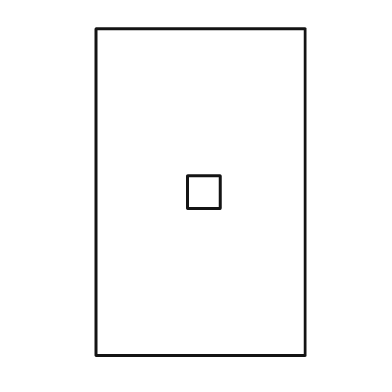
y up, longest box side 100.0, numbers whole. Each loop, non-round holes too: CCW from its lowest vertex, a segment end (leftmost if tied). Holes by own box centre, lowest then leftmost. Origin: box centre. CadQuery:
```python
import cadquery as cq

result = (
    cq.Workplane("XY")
    .moveTo(-32.0, -50.0)
    .lineTo(32.0, -50.0)
    .lineTo(32.0, 50.0)
    .lineTo(-32.0, 50.0)
    .close()
    .moveTo(-4.0, -5.0)
    .lineTo(6.0, -5.0)
    .lineTo(6.0, 5.0)
    .lineTo(-4.0, 5.0)
    .close()
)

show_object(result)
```